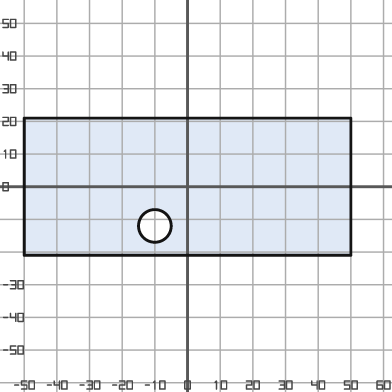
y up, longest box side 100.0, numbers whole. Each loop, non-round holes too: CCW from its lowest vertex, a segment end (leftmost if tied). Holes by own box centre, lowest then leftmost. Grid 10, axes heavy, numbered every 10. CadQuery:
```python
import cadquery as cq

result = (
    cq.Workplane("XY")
    .moveTo(-50.0, -21.0)
    .lineTo(50.0, -21.0)
    .lineTo(50.0, 21.0)
    .lineTo(-50.0, 21.0)
    .close()
    .moveTo(-10.0, -12.0)
    .circle(5.0)
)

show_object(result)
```